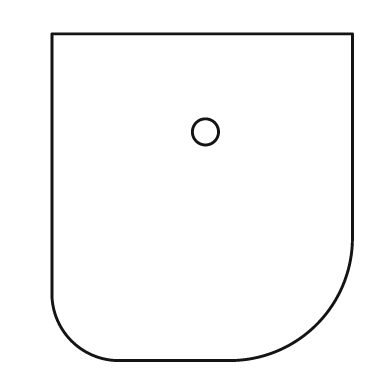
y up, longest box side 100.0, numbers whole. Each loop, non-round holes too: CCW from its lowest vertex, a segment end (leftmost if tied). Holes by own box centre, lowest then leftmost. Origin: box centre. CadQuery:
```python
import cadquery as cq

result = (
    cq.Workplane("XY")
    .moveTo(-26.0, -50.0)
    .lineTo(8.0, -50.0)
    .threePointArc((35.0, -39.0), (46.0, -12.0))
    .lineTo(46.0, 50.0)
    .lineTo(-46.0, 50.0)
    .lineTo(-46.0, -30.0)
    .threePointArc((-40.0, -44.0), (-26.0, -50.0))
    .close()
    .moveTo(1.0, 20.0)
    .circle(4.0)
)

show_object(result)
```